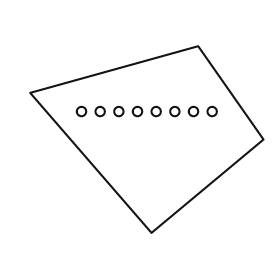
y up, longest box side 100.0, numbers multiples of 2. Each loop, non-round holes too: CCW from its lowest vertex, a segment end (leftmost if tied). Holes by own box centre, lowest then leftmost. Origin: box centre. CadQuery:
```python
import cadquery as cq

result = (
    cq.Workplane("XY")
    .moveTo(2.0, -40.0)
    .lineTo(50.0, 0.0)
    .lineTo(22.0, 40.0)
    .lineTo(-50.0, 20.0)
    .close()
    .moveTo(-28.0, 12.0)
    .circle(2.0)
    .moveTo(-20.0, 12.0)
    .circle(2.0)
    .moveTo(-12.0, 12.0)
    .circle(2.0)
    .moveTo(-4.0, 12.0)
    .circle(2.0)
    .moveTo(4.0, 12.0)
    .circle(2.0)
    .moveTo(12.0, 12.0)
    .circle(2.0)
    .moveTo(20.0, 12.0)
    .circle(2.0)
    .moveTo(28.0, 12.0)
    .circle(2.0)
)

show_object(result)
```